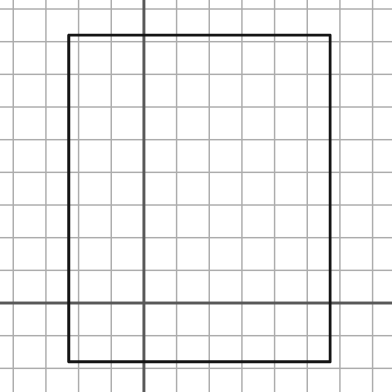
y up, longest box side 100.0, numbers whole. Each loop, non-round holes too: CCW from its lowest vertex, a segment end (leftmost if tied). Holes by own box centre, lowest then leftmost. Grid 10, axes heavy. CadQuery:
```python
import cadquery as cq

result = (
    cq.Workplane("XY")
    .moveTo(-23.0, -18.0)
    .lineTo(57.0, -18.0)
    .lineTo(57.0, 82.0)
    .lineTo(-23.0, 82.0)
    .close()
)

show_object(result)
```